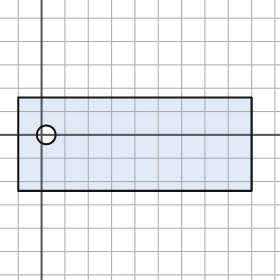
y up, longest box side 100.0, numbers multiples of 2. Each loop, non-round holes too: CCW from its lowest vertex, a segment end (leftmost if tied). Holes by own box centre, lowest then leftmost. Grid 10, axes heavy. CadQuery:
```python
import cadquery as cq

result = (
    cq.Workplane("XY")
    .moveTo(-10.0, -24.0)
    .lineTo(90.0, -24.0)
    .lineTo(90.0, 16.0)
    .lineTo(-10.0, 16.0)
    .close()
    .moveTo(2.0, 0.0)
    .circle(4.0)
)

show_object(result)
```